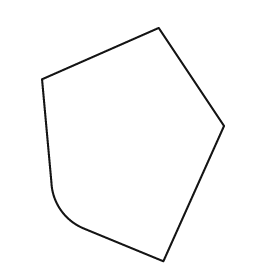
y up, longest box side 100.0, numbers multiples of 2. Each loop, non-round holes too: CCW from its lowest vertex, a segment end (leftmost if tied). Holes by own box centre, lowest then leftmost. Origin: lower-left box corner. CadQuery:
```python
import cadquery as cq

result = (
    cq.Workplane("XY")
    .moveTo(52.0, 0.0)
    .lineTo(78.0, 58.0)
    .lineTo(50.0, 100.0)
    .lineTo(0.0, 78.0)
    .lineTo(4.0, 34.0)
    .threePointArc((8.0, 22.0), (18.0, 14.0))
    .close()
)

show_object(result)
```